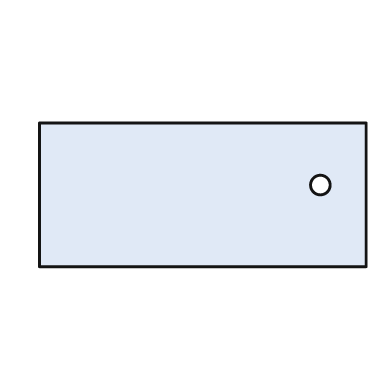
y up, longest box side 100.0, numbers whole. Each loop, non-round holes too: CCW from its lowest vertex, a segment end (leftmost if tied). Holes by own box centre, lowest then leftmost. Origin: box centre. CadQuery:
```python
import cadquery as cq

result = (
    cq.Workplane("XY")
    .moveTo(-50.0, -22.0)
    .lineTo(50.0, -22.0)
    .lineTo(50.0, 22.0)
    .lineTo(-50.0, 22.0)
    .close()
    .moveTo(36.0, 3.0)
    .circle(3.0)
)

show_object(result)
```